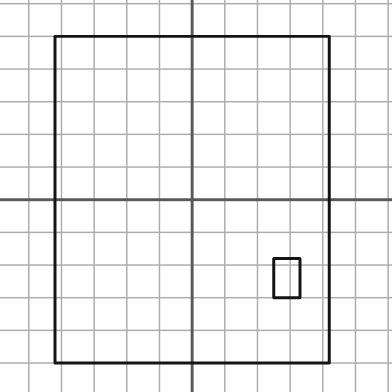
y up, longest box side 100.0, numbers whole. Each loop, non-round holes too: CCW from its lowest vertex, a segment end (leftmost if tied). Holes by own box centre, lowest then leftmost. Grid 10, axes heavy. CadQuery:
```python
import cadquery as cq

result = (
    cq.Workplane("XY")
    .moveTo(-42.0, -50.0)
    .lineTo(42.0, -50.0)
    .lineTo(42.0, 50.0)
    .lineTo(-42.0, 50.0)
    .close()
    .moveTo(25.0, -30.0)
    .lineTo(33.0, -30.0)
    .lineTo(33.0, -18.0)
    .lineTo(25.0, -18.0)
    .close()
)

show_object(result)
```